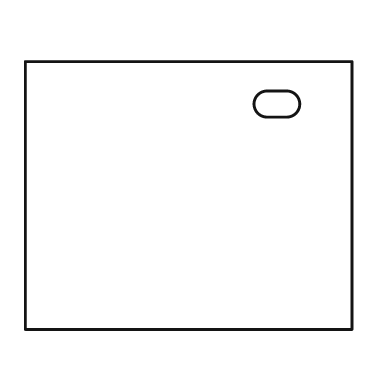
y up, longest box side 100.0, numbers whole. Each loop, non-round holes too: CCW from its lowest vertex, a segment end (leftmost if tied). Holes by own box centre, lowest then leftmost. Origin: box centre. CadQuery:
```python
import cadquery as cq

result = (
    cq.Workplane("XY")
    .moveTo(-50.0, -41.0)
    .lineTo(50.0, -41.0)
    .lineTo(50.0, 41.0)
    .lineTo(-50.0, 41.0)
    .close()
    .moveTo(24.0, 24.0)
    .lineTo(30.0, 24.0)
    .threePointArc((34.0, 28.0), (30.0, 32.0))
    .lineTo(24.0, 32.0)
    .threePointArc((20.0, 28.0), (24.0, 24.0))
    .close()
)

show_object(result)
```